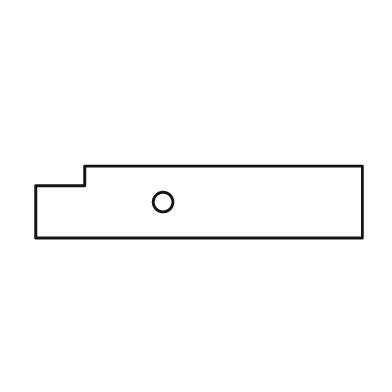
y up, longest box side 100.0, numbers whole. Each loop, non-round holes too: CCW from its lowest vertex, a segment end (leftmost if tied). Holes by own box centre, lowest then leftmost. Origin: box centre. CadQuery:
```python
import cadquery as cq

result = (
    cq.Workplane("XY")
    .moveTo(-50.0, -11.0)
    .lineTo(50.0, -11.0)
    .lineTo(50.0, 11.0)
    .lineTo(-35.0, 11.0)
    .lineTo(-35.0, 5.0)
    .lineTo(-50.0, 5.0)
    .close()
    .moveTo(-11.0, 0.0)
    .circle(3.0)
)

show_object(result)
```